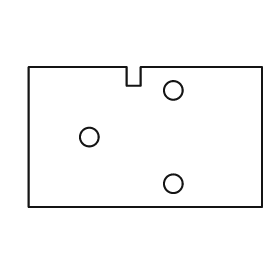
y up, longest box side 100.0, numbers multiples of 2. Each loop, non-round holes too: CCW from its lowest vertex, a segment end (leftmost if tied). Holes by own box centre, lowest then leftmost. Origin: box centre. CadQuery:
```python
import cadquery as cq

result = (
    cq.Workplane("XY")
    .moveTo(-50.0, -30.0)
    .lineTo(50.0, -30.0)
    .lineTo(50.0, 30.0)
    .lineTo(-2.0, 30.0)
    .lineTo(-2.0, 22.0)
    .lineTo(-8.0, 22.0)
    .lineTo(-8.0, 30.0)
    .lineTo(-50.0, 30.0)
    .close()
    .moveTo(12.0, -20.0)
    .circle(4.0)
    .moveTo(-24.0, 0.0)
    .circle(4.0)
    .moveTo(12.0, 20.0)
    .circle(4.0)
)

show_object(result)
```